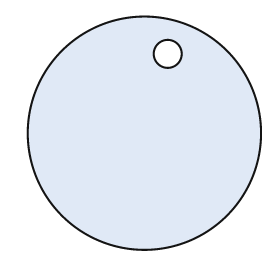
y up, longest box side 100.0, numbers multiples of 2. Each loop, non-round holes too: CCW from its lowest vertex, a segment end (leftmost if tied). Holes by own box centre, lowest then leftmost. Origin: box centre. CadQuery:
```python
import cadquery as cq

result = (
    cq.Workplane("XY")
    .moveTo(0.0, 0.0)
    .circle(50.0)
    .moveTo(10.0, 34.0)
    .circle(6.0)
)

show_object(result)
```